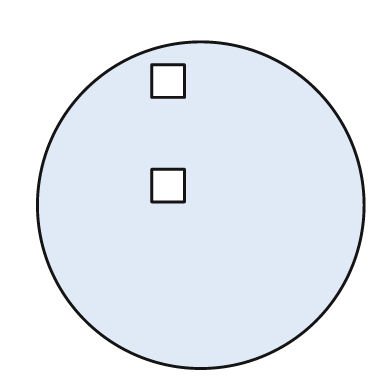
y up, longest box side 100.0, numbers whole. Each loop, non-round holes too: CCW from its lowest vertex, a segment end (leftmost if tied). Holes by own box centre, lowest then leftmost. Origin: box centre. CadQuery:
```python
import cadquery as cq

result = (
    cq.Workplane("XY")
    .moveTo(0.0, 0.0)
    .circle(50.0)
    .moveTo(-15.0, 1.0)
    .lineTo(-5.0, 1.0)
    .lineTo(-5.0, 11.0)
    .lineTo(-15.0, 11.0)
    .close()
    .moveTo(-15.0, 33.0)
    .lineTo(-5.0, 33.0)
    .lineTo(-5.0, 43.0)
    .lineTo(-15.0, 43.0)
    .close()
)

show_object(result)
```